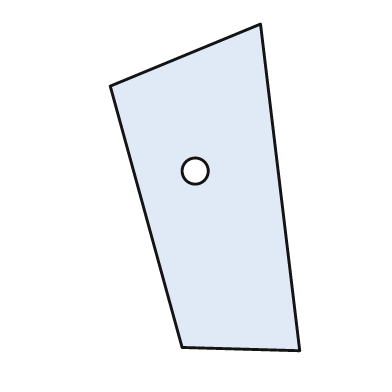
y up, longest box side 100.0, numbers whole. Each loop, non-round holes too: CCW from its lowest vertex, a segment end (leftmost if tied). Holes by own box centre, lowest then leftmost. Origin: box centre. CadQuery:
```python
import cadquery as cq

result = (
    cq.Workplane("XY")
    .moveTo(29.0, -50.0)
    .lineTo(17.0, 50.0)
    .lineTo(-29.0, 31.0)
    .lineTo(-7.0, -49.0)
    .close()
    .moveTo(-3.0, 5.0)
    .circle(4.0)
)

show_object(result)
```